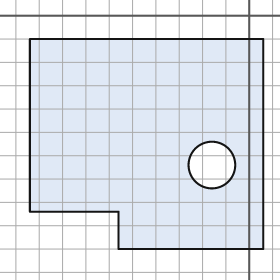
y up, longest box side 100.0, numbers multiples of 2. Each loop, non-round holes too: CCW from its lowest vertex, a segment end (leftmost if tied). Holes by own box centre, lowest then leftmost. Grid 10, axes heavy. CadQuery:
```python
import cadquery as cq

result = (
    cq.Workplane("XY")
    .moveTo(-56.0, -100.0)
    .lineTo(6.0, -100.0)
    .lineTo(6.0, -10.0)
    .lineTo(-94.0, -10.0)
    .lineTo(-94.0, -84.0)
    .lineTo(-56.0, -84.0)
    .close()
    .moveTo(-16.0, -64.0)
    .circle(10.0)
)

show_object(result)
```